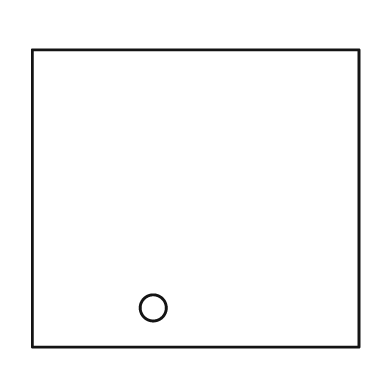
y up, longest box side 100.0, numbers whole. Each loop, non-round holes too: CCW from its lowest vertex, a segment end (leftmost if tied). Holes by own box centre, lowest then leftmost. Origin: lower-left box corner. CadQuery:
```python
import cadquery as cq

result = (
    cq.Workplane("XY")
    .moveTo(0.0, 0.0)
    .lineTo(100.0, 0.0)
    .lineTo(100.0, 91.0)
    .lineTo(0.0, 91.0)
    .close()
    .moveTo(37.0, 12.0)
    .circle(4.0)
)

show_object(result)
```